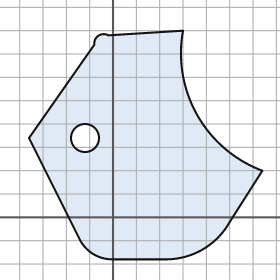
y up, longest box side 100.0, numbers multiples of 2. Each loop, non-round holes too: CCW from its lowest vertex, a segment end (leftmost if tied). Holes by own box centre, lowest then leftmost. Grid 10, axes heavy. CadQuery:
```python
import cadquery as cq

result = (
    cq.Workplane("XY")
    .moveTo(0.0, -18.0)
    .lineTo(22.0, -18.0)
    .threePointArc((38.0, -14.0), (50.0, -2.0))
    .lineTo(64.0, 20.0)
    .threePointArc((36.0, 44.0), (30.0, 80.0))
    .lineTo(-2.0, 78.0)
    .threePointArc((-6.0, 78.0), (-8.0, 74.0))
    .lineTo(-36.0, 34.0)
    .lineTo(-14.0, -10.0)
    .threePointArc((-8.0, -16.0), (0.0, -18.0))
    .close()
    .moveTo(-12.0, 34.0)
    .circle(6.0)
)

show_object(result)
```